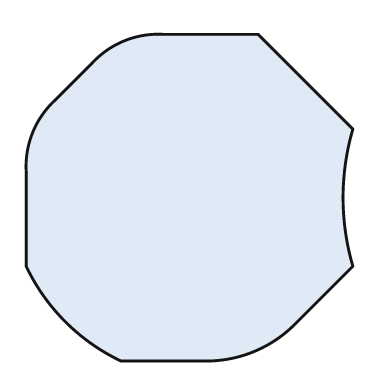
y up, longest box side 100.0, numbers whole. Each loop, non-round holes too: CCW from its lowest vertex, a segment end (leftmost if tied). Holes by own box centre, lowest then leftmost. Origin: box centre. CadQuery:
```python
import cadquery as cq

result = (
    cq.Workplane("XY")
    .moveTo(-21.0, -50.0)
    .lineTo(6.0, -50.0)
    .threePointArc((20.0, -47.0), (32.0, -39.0))
    .lineTo(50.0, -21.0)
    .threePointArc((47.0, 0.0), (50.0, 21.0))
    .lineTo(21.0, 50.0)
    .lineTo(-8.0, 50.0)
    .threePointArc((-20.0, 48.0), (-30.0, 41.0))
    .lineTo(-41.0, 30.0)
    .threePointArc((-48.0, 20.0), (-50.0, 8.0))
    .lineTo(-50.0, -21.0)
    .threePointArc((-38.0, -38.0), (-21.0, -50.0))
    .close()
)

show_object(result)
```